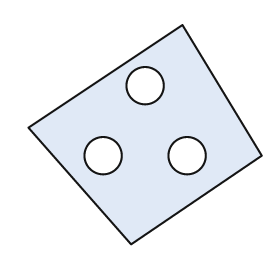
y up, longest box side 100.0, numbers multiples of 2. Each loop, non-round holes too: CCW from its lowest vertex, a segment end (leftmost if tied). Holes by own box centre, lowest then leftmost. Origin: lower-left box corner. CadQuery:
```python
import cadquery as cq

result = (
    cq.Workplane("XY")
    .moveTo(44.0, 0.0)
    .lineTo(100.0, 38.0)
    .lineTo(66.0, 94.0)
    .lineTo(0.0, 50.0)
    .close()
    .moveTo(32.0, 38.0)
    .circle(8.0)
    .moveTo(68.0, 38.0)
    .circle(8.0)
    .moveTo(50.0, 68.0)
    .circle(8.0)
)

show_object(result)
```